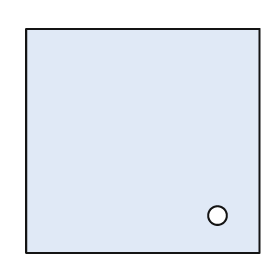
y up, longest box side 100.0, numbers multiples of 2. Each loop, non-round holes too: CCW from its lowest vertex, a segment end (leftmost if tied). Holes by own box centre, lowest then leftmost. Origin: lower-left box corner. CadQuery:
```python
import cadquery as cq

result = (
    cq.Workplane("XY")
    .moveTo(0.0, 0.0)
    .lineTo(100.0, 0.0)
    .lineTo(100.0, 96.0)
    .lineTo(0.0, 96.0)
    .close()
    .moveTo(82.0, 16.0)
    .circle(4.0)
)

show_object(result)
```